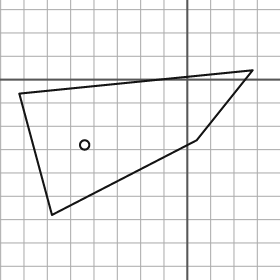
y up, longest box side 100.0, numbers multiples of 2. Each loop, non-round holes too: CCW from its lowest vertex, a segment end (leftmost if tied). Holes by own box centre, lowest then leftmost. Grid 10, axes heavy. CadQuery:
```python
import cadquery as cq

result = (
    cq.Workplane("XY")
    .moveTo(-58.0, -58.0)
    .lineTo(4.0, -26.0)
    .lineTo(28.0, 4.0)
    .lineTo(-72.0, -6.0)
    .close()
    .moveTo(-44.0, -28.0)
    .circle(2.0)
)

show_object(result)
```